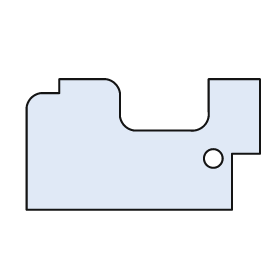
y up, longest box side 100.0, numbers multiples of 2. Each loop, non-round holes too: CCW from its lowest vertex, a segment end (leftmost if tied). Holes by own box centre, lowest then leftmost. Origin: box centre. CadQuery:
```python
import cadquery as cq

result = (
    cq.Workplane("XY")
    .moveTo(-50.0, -28.0)
    .lineTo(38.0, -28.0)
    .lineTo(38.0, -4.0)
    .lineTo(50.0, -4.0)
    .lineTo(50.0, 28.0)
    .lineTo(28.0, 28.0)
    .lineTo(28.0, 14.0)
    .threePointArc((26.0, 8.0), (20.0, 6.0))
    .lineTo(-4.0, 6.0)
    .threePointArc((-8.0, 8.0), (-10.0, 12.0))
    .lineTo(-10.0, 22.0)
    .threePointArc((-12.0, 26.0), (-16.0, 28.0))
    .lineTo(-36.0, 28.0)
    .lineTo(-36.0, 22.0)
    .lineTo(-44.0, 22.0)
    .threePointArc((-48.0, 20.0), (-50.0, 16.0))
    .close()
    .moveTo(30.0, -6.0)
    .circle(4.0)
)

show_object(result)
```